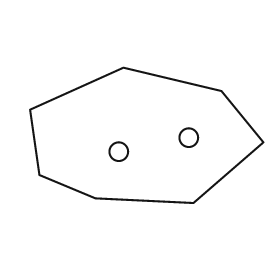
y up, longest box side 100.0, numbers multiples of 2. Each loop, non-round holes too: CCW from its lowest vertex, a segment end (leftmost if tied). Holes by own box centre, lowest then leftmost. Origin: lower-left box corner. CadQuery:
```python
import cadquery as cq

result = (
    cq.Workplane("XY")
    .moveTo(70.0, 0.0)
    .lineTo(100.0, 26.0)
    .lineTo(82.0, 48.0)
    .lineTo(40.0, 58.0)
    .lineTo(0.0, 40.0)
    .lineTo(4.0, 12.0)
    .lineTo(28.0, 2.0)
    .close()
    .moveTo(38.0, 22.0)
    .circle(4.0)
    .moveTo(68.0, 28.0)
    .circle(4.0)
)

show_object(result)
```